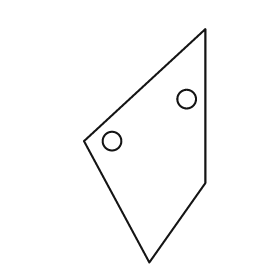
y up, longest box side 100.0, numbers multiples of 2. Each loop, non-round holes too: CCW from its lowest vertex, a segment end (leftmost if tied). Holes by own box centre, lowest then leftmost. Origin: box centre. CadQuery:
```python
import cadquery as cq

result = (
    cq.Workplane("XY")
    .moveTo(2.0, -50.0)
    .lineTo(26.0, -16.0)
    .lineTo(26.0, 50.0)
    .lineTo(-26.0, 2.0)
    .close()
    .moveTo(-14.0, 2.0)
    .circle(4.0)
    .moveTo(18.0, 20.0)
    .circle(4.0)
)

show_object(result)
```